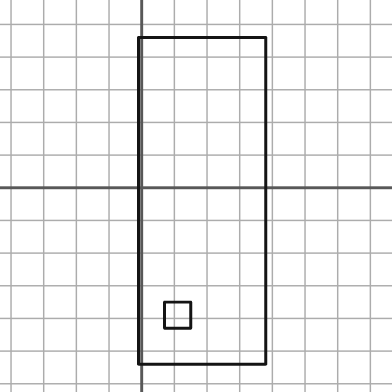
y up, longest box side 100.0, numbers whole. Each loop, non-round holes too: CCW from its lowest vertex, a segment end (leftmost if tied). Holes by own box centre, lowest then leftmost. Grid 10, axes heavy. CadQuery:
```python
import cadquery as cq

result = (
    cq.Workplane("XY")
    .moveTo(-1.0, -54.0)
    .lineTo(38.0, -54.0)
    .lineTo(38.0, 46.0)
    .lineTo(-1.0, 46.0)
    .close()
    .moveTo(7.0, -43.0)
    .lineTo(15.0, -43.0)
    .lineTo(15.0, -35.0)
    .lineTo(7.0, -35.0)
    .close()
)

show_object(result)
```